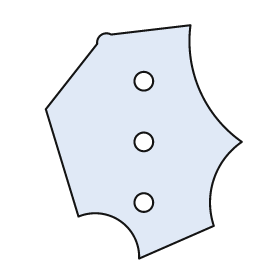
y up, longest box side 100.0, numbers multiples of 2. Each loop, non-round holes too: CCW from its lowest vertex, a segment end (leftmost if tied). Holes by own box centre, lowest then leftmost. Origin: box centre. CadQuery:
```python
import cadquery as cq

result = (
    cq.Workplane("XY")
    .moveTo(-2.0, -50.0)
    .lineTo(30.0, -36.0)
    .threePointArc((30.0, -16.0), (42.0, 0.0))
    .threePointArc((24.0, 22.0), (20.0, 50.0))
    .lineTo(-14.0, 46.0)
    .threePointArc((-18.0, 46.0), (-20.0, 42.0))
    .lineTo(-42.0, 14.0)
    .lineTo(-28.0, -32.0)
    .threePointArc((-10.0, -34.0), (-2.0, -50.0))
    .close()
    .moveTo(0.0, -26.0)
    .circle(4.0)
    .moveTo(0.0, 0.0)
    .circle(4.0)
    .moveTo(0.0, 26.0)
    .circle(4.0)
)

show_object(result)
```